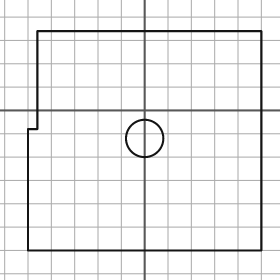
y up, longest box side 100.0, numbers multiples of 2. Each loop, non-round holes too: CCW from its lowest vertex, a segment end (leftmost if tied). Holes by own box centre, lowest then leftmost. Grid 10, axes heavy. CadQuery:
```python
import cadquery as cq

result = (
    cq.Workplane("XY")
    .moveTo(-50.0, -60.0)
    .lineTo(50.0, -60.0)
    .lineTo(50.0, 34.0)
    .lineTo(-46.0, 34.0)
    .lineTo(-46.0, -8.0)
    .lineTo(-50.0, -8.0)
    .close()
    .moveTo(0.0, -12.0)
    .circle(8.0)
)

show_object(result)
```